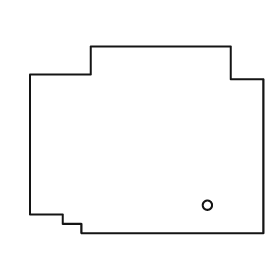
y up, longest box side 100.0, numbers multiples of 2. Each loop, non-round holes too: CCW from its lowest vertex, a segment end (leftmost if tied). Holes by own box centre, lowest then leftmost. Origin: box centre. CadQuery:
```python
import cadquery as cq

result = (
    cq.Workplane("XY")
    .moveTo(-28.0, -40.0)
    .lineTo(50.0, -40.0)
    .lineTo(50.0, 26.0)
    .lineTo(36.0, 26.0)
    .lineTo(36.0, 40.0)
    .lineTo(-24.0, 40.0)
    .lineTo(-24.0, 28.0)
    .lineTo(-50.0, 28.0)
    .lineTo(-50.0, -32.0)
    .lineTo(-36.0, -32.0)
    .lineTo(-36.0, -36.0)
    .lineTo(-28.0, -36.0)
    .close()
    .moveTo(26.0, -28.0)
    .circle(2.0)
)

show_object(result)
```